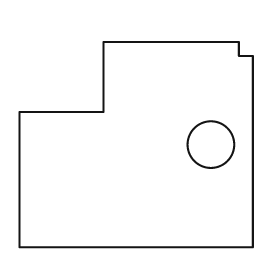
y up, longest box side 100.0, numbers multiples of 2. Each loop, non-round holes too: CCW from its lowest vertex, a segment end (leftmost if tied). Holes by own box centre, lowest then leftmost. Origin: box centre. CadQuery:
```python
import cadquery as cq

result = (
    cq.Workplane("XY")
    .moveTo(-50.0, -44.0)
    .lineTo(50.0, -44.0)
    .lineTo(50.0, 38.0)
    .lineTo(44.0, 38.0)
    .lineTo(44.0, 44.0)
    .lineTo(-14.0, 44.0)
    .lineTo(-14.0, 14.0)
    .lineTo(-50.0, 14.0)
    .close()
    .moveTo(32.0, 0.0)
    .circle(10.0)
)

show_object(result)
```